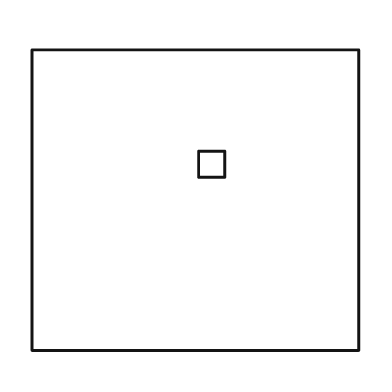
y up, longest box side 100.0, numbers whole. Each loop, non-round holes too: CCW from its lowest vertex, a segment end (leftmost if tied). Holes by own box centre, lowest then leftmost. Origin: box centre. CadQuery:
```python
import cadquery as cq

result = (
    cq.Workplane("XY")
    .moveTo(-50.0, -46.0)
    .lineTo(50.0, -46.0)
    .lineTo(50.0, 46.0)
    .lineTo(-50.0, 46.0)
    .close()
    .moveTo(1.0, 7.0)
    .lineTo(9.0, 7.0)
    .lineTo(9.0, 15.0)
    .lineTo(1.0, 15.0)
    .close()
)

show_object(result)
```